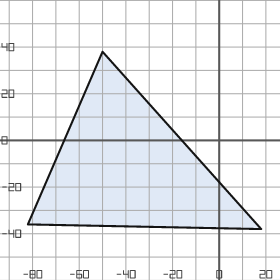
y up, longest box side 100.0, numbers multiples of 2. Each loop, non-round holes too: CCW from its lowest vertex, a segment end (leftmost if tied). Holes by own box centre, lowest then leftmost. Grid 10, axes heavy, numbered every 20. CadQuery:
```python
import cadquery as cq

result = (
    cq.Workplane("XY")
    .moveTo(18.0, -38.0)
    .lineTo(-50.0, 38.0)
    .lineTo(-82.0, -36.0)
    .close()
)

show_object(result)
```